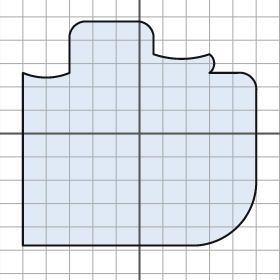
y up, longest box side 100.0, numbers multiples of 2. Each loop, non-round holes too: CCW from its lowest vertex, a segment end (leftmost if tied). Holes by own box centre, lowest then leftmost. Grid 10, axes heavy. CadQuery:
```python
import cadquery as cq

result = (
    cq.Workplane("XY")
    .moveTo(-50.0, -48.0)
    .lineTo(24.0, -48.0)
    .threePointArc((42.0, -40.0), (50.0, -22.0))
    .lineTo(50.0, 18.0)
    .threePointArc((48.0, 24.0), (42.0, 26.0))
    .lineTo(30.0, 26.0)
    .threePointArc((32.0, 30.0), (30.0, 34.0))
    .threePointArc((18.0, 32.0), (6.0, 34.0))
    .lineTo(6.0, 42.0)
    .threePointArc((4.0, 46.0), (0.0, 48.0))
    .lineTo(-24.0, 48.0)
    .threePointArc((-28.0, 46.0), (-30.0, 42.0))
    .lineTo(-30.0, 26.0)
    .threePointArc((-40.0, 24.0), (-50.0, 26.0))
    .close()
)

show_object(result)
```